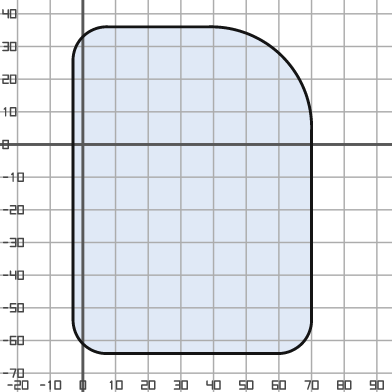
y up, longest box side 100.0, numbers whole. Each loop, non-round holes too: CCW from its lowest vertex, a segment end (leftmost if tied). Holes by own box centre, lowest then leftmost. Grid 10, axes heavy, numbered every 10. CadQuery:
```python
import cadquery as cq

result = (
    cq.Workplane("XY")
    .moveTo(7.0, -64.0)
    .lineTo(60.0, -64.0)
    .threePointArc((67.0, -61.0), (70.0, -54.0))
    .lineTo(70.0, 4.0)
    .threePointArc((61.0, 27.0), (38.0, 36.0))
    .lineTo(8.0, 36.0)
    .threePointArc((0.0, 33.0), (-3.0, 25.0))
    .lineTo(-3.0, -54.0)
    .threePointArc((0.0, -61.0), (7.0, -64.0))
    .close()
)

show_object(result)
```